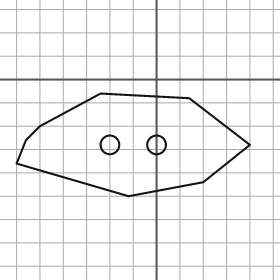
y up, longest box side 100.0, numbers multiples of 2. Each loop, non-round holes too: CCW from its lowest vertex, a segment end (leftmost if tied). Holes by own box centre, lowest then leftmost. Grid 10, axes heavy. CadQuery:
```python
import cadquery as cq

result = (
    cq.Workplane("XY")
    .moveTo(-12.0, -50.0)
    .lineTo(20.0, -44.0)
    .lineTo(40.0, -28.0)
    .lineTo(14.0, -8.0)
    .lineTo(-24.0, -6.0)
    .lineTo(-50.0, -20.0)
    .lineTo(-56.0, -26.0)
    .lineTo(-60.0, -36.0)
    .close()
    .moveTo(-20.0, -28.0)
    .circle(4.0)
    .moveTo(0.0, -28.0)
    .circle(4.0)
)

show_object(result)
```